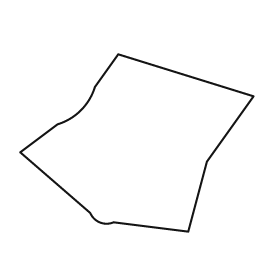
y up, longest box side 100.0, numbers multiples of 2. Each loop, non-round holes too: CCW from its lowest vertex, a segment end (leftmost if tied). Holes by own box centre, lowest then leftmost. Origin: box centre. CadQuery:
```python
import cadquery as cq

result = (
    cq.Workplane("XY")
    .moveTo(22.0, -38.0)
    .lineTo(30.0, -8.0)
    .lineTo(50.0, 20.0)
    .lineTo(-8.0, 38.0)
    .lineTo(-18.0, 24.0)
    .threePointArc((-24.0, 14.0), (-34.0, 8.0))
    .lineTo(-50.0, -4.0)
    .lineTo(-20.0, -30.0)
    .threePointArc((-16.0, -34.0), (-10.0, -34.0))
    .close()
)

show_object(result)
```